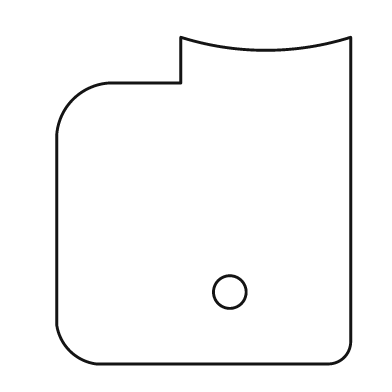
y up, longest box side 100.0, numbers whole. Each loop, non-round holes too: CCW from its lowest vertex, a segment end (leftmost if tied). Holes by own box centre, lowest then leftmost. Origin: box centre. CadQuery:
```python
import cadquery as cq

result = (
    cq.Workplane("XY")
    .moveTo(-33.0, -50.0)
    .lineTo(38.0, -50.0)
    .threePointArc((43.0, -48.0), (45.0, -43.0))
    .lineTo(45.0, 50.0)
    .threePointArc((19.0, 46.0), (-7.0, 50.0))
    .lineTo(-7.0, 36.0)
    .lineTo(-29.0, 36.0)
    .threePointArc((-40.0, 31.0), (-45.0, 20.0))
    .lineTo(-45.0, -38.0)
    .threePointArc((-41.0, -46.0), (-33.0, -50.0))
    .close()
    .moveTo(8.0, -28.0)
    .circle(5.0)
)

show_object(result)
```